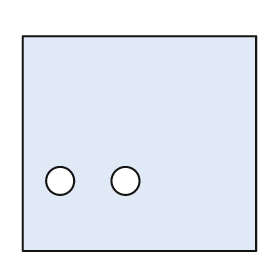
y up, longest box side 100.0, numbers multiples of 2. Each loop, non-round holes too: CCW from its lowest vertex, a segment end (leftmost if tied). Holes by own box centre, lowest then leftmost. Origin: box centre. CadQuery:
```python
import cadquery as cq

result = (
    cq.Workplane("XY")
    .moveTo(-50.0, -46.0)
    .lineTo(50.0, -46.0)
    .lineTo(50.0, 46.0)
    .lineTo(-50.0, 46.0)
    .close()
    .moveTo(-34.0, -16.0)
    .circle(6.0)
    .moveTo(-6.0, -16.0)
    .circle(6.0)
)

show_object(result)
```